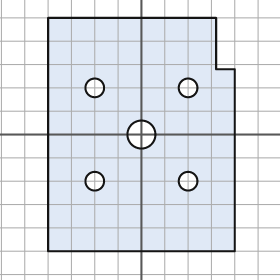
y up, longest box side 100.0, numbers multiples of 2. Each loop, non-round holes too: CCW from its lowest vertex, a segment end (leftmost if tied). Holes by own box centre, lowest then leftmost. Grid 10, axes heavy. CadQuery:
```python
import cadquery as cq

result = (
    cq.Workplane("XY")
    .moveTo(-40.0, -50.0)
    .lineTo(40.0, -50.0)
    .lineTo(40.0, 28.0)
    .lineTo(32.0, 28.0)
    .lineTo(32.0, 50.0)
    .lineTo(-40.0, 50.0)
    .close()
    .moveTo(-20.0, -20.0)
    .circle(4.0)
    .moveTo(20.0, -20.0)
    .circle(4.0)
    .moveTo(0.0, 0.0)
    .circle(6.0)
    .moveTo(-20.0, 20.0)
    .circle(4.0)
    .moveTo(20.0, 20.0)
    .circle(4.0)
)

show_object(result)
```